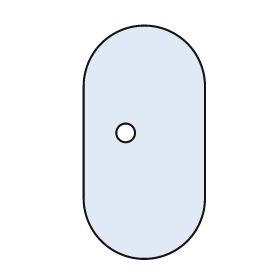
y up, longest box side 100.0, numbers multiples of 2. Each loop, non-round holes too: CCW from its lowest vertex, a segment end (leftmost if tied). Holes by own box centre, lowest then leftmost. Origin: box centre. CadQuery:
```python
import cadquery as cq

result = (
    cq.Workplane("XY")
    .moveTo(-26.0, -24.0)
    .threePointArc((0.0, -50.0), (26.0, -24.0))
    .lineTo(26.0, 24.0)
    .threePointArc((0.0, 50.0), (-26.0, 24.0))
    .close()
    .moveTo(-8.0, 4.0)
    .circle(4.0)
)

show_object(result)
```